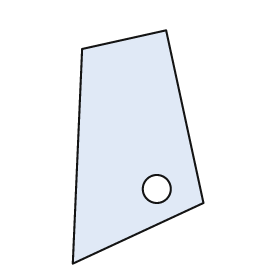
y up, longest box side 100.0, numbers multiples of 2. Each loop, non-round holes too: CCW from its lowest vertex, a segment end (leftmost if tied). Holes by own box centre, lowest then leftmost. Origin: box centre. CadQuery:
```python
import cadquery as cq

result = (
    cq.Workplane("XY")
    .moveTo(-28.0, -50.0)
    .lineTo(28.0, -24.0)
    .lineTo(12.0, 50.0)
    .lineTo(-24.0, 42.0)
    .close()
    .moveTo(8.0, -18.0)
    .circle(6.0)
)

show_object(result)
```